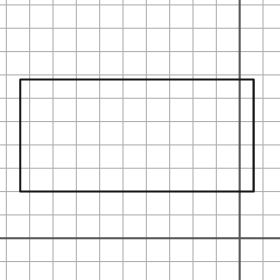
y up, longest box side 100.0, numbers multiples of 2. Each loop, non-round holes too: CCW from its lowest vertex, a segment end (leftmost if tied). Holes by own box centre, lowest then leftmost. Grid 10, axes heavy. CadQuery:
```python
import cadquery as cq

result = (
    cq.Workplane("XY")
    .moveTo(-94.0, 20.0)
    .lineTo(6.0, 20.0)
    .lineTo(6.0, 68.0)
    .lineTo(-94.0, 68.0)
    .close()
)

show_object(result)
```